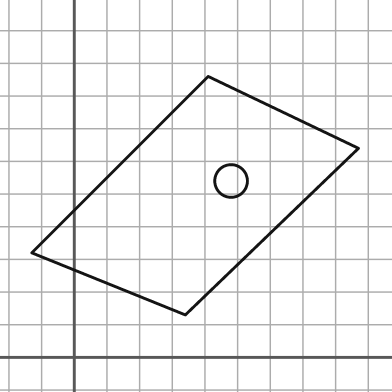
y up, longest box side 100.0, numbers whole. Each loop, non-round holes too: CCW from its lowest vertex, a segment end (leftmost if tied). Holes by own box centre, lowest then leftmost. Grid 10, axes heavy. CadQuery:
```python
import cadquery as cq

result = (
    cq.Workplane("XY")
    .moveTo(34.0, 13.0)
    .lineTo(87.0, 64.0)
    .lineTo(41.0, 86.0)
    .lineTo(-13.0, 32.0)
    .close()
    .moveTo(48.0, 54.0)
    .circle(5.0)
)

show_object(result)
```